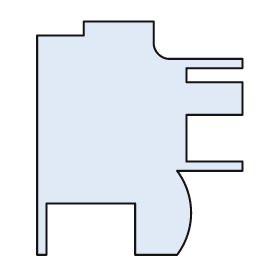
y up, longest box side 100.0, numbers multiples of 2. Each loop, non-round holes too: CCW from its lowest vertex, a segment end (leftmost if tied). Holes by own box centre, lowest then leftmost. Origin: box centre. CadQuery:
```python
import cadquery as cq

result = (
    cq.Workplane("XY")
    .moveTo(-44.0, -50.0)
    .lineTo(-40.0, -50.0)
    .lineTo(-40.0, -28.0)
    .lineTo(-2.0, -28.0)
    .lineTo(-2.0, -50.0)
    .lineTo(16.0, -50.0)
    .threePointArc((22.0, -32.0), (16.0, -14.0))
    .lineTo(44.0, -14.0)
    .lineTo(44.0, -10.0)
    .lineTo(20.0, -10.0)
    .lineTo(20.0, 10.0)
    .lineTo(44.0, 10.0)
    .lineTo(44.0, 24.0)
    .lineTo(20.0, 24.0)
    .lineTo(20.0, 30.0)
    .lineTo(44.0, 30.0)
    .lineTo(44.0, 34.0)
    .lineTo(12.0, 34.0)
    .threePointArc((8.0, 36.0), (6.0, 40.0))
    .lineTo(6.0, 50.0)
    .lineTo(-24.0, 50.0)
    .lineTo(-24.0, 44.0)
    .lineTo(-44.0, 44.0)
    .close()
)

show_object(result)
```